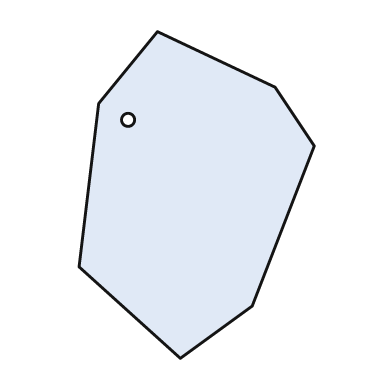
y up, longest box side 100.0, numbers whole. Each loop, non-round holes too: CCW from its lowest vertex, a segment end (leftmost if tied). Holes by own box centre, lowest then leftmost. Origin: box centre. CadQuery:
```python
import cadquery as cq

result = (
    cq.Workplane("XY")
    .moveTo(-5.0, -50.0)
    .lineTo(17.0, -34.0)
    .lineTo(36.0, 15.0)
    .lineTo(24.0, 33.0)
    .lineTo(-12.0, 50.0)
    .lineTo(-30.0, 28.0)
    .lineTo(-36.0, -22.0)
    .close()
    .moveTo(-21.0, 23.0)
    .circle(2.0)
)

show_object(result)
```